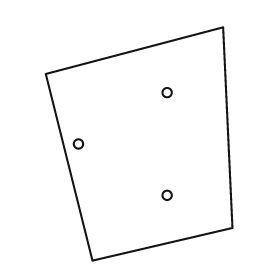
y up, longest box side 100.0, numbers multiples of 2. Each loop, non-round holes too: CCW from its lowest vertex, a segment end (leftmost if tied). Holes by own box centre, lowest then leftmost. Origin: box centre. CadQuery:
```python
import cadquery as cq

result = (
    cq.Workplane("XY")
    .moveTo(-20.0, -50.0)
    .lineTo(40.0, -36.0)
    .lineTo(36.0, 50.0)
    .lineTo(-40.0, 30.0)
    .close()
    .moveTo(12.0, -22.0)
    .circle(2.0)
    .moveTo(-26.0, 0.0)
    .circle(2.0)
    .moveTo(12.0, 22.0)
    .circle(2.0)
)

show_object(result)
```